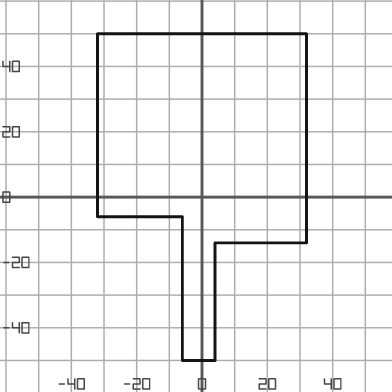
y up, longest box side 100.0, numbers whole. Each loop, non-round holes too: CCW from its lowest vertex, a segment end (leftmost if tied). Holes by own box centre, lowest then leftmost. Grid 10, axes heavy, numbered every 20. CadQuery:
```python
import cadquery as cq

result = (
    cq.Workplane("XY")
    .moveTo(-6.0, -50.0)
    .lineTo(4.0, -50.0)
    .lineTo(4.0, -14.0)
    .lineTo(32.0, -14.0)
    .lineTo(32.0, 50.0)
    .lineTo(-32.0, 50.0)
    .lineTo(-32.0, -6.0)
    .lineTo(-6.0, -6.0)
    .close()
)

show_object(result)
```